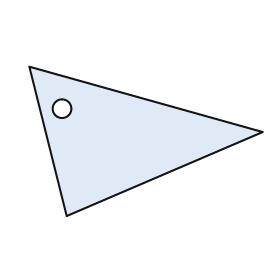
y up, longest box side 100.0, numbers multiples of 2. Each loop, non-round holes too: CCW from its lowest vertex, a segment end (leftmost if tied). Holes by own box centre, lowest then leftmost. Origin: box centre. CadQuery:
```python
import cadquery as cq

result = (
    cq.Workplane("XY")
    .moveTo(-34.0, -32.0)
    .lineTo(50.0, 4.0)
    .lineTo(-50.0, 32.0)
    .close()
    .moveTo(-36.0, 14.0)
    .circle(4.0)
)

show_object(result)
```